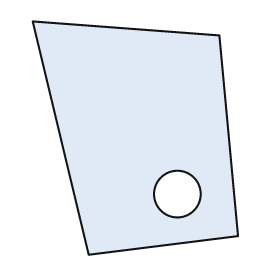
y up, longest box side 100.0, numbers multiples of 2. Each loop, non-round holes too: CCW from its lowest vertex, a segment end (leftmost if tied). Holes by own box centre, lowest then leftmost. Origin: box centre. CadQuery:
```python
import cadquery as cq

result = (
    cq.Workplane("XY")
    .moveTo(-20.0, -50.0)
    .lineTo(44.0, -42.0)
    .lineTo(36.0, 44.0)
    .lineTo(-44.0, 50.0)
    .close()
    .moveTo(18.0, -24.0)
    .circle(10.0)
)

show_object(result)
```